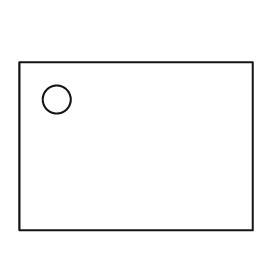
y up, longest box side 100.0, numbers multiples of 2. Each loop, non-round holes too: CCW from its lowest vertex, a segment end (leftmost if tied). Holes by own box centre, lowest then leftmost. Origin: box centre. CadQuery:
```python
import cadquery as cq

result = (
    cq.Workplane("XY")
    .moveTo(-50.0, -36.0)
    .lineTo(50.0, -36.0)
    .lineTo(50.0, 36.0)
    .lineTo(-50.0, 36.0)
    .close()
    .moveTo(-34.0, 20.0)
    .circle(6.0)
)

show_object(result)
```